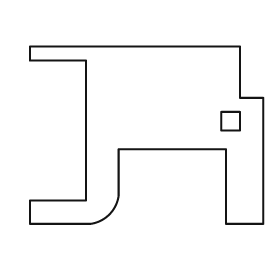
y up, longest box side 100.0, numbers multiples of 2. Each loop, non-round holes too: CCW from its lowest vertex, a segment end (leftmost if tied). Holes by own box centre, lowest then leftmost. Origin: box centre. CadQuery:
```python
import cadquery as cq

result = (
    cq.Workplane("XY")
    .moveTo(-50.0, -38.0)
    .lineTo(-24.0, -38.0)
    .threePointArc((-16.0, -34.0), (-12.0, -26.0))
    .lineTo(-12.0, -6.0)
    .lineTo(34.0, -6.0)
    .lineTo(34.0, -38.0)
    .lineTo(50.0, -38.0)
    .lineTo(50.0, 16.0)
    .lineTo(40.0, 16.0)
    .lineTo(40.0, 38.0)
    .lineTo(-50.0, 38.0)
    .lineTo(-50.0, 32.0)
    .lineTo(-26.0, 32.0)
    .lineTo(-26.0, -28.0)
    .lineTo(-50.0, -28.0)
    .close()
    .moveTo(32.0, 2.0)
    .lineTo(40.0, 2.0)
    .lineTo(40.0, 10.0)
    .lineTo(32.0, 10.0)
    .close()
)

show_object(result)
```